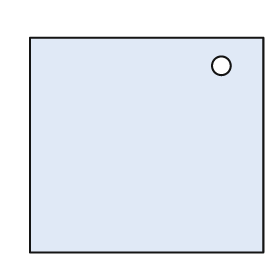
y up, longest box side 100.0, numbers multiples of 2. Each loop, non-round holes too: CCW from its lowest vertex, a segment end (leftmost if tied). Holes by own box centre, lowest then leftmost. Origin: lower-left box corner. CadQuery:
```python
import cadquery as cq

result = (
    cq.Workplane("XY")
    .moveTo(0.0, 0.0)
    .lineTo(100.0, 0.0)
    .lineTo(100.0, 92.0)
    .lineTo(0.0, 92.0)
    .close()
    .moveTo(82.0, 80.0)
    .circle(4.0)
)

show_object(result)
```